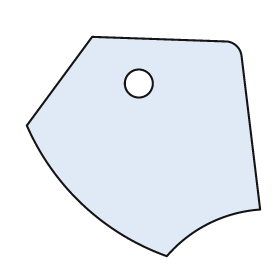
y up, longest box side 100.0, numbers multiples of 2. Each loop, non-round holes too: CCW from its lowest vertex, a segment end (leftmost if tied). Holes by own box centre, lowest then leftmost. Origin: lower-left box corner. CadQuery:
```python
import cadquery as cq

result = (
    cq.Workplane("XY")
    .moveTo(60.0, 0.0)
    .threePointArc((78.0, 14.0), (100.0, 20.0))
    .lineTo(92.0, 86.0)
    .threePointArc((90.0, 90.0), (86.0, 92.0))
    .lineTo(28.0, 94.0)
    .lineTo(0.0, 56.0)
    .threePointArc((24.0, 22.0), (60.0, 0.0))
    .close()
    .moveTo(48.0, 74.0)
    .circle(6.0)
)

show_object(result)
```